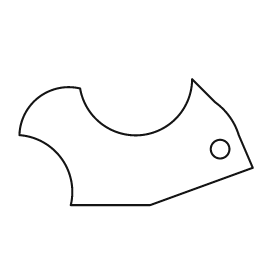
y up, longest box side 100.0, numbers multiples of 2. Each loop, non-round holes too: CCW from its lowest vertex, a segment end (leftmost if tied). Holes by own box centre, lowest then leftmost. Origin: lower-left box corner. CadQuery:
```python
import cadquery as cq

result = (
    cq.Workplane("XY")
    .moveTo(22.0, 0.0)
    .lineTo(56.0, 0.0)
    .lineTo(100.0, 16.0)
    .lineTo(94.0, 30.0)
    .threePointArc((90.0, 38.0), (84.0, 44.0))
    .lineTo(74.0, 54.0)
    .threePointArc((52.0, 30.0), (26.0, 50.0))
    .threePointArc((8.0, 46.0), (0.0, 30.0))
    .threePointArc((18.0, 20.0), (22.0, 0.0))
    .close()
    .moveTo(86.0, 24.0)
    .circle(4.0)
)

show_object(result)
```